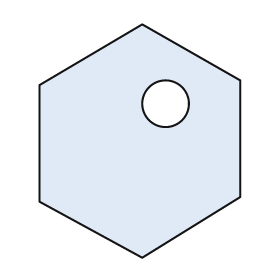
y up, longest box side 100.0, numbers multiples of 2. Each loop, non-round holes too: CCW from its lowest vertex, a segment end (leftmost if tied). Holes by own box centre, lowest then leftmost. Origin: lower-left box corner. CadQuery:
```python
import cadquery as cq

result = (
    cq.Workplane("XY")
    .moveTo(44.0, 0.0)
    .lineTo(86.0, 26.0)
    .lineTo(86.0, 76.0)
    .lineTo(44.0, 100.0)
    .lineTo(0.0, 74.0)
    .lineTo(0.0, 24.0)
    .close()
    .moveTo(54.0, 66.0)
    .circle(10.0)
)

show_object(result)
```